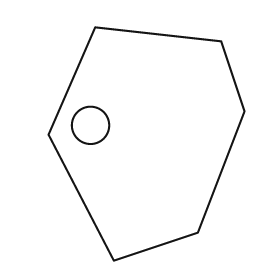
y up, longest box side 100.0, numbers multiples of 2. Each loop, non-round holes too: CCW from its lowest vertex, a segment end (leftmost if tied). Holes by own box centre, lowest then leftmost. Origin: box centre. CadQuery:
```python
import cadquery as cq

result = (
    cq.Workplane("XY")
    .moveTo(-14.0, -50.0)
    .lineTo(22.0, -38.0)
    .lineTo(42.0, 14.0)
    .lineTo(32.0, 44.0)
    .lineTo(-22.0, 50.0)
    .lineTo(-42.0, 4.0)
    .close()
    .moveTo(-24.0, 8.0)
    .circle(8.0)
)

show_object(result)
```